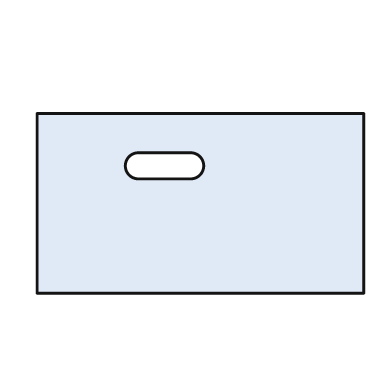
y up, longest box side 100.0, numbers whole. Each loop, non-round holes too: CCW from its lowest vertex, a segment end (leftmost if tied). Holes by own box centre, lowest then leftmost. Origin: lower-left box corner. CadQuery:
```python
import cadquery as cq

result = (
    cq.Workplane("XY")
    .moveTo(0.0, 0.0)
    .lineTo(100.0, 0.0)
    .lineTo(100.0, 55.0)
    .lineTo(0.0, 55.0)
    .close()
    .moveTo(31.0, 35.0)
    .lineTo(47.0, 35.0)
    .threePointArc((51.0, 39.0), (47.0, 43.0))
    .lineTo(31.0, 43.0)
    .threePointArc((27.0, 39.0), (31.0, 35.0))
    .close()
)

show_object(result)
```